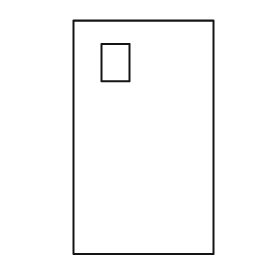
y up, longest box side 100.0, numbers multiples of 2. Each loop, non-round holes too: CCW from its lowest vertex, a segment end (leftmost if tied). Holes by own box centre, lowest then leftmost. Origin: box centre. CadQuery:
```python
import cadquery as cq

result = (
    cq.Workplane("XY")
    .moveTo(-30.0, -50.0)
    .lineTo(30.0, -50.0)
    .lineTo(30.0, 50.0)
    .lineTo(-30.0, 50.0)
    .close()
    .moveTo(-18.0, 24.0)
    .lineTo(-6.0, 24.0)
    .lineTo(-6.0, 40.0)
    .lineTo(-18.0, 40.0)
    .close()
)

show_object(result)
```